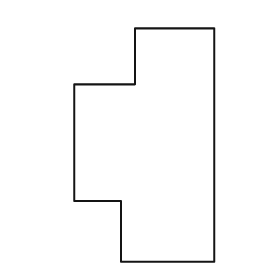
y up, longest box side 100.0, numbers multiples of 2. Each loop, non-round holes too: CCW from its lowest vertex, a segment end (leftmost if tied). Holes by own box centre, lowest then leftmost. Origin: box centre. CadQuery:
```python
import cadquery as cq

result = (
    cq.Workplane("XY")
    .moveTo(-10.0, -50.0)
    .lineTo(30.0, -50.0)
    .lineTo(30.0, 50.0)
    .lineTo(-4.0, 50.0)
    .lineTo(-4.0, 26.0)
    .lineTo(-30.0, 26.0)
    .lineTo(-30.0, -24.0)
    .lineTo(-10.0, -24.0)
    .close()
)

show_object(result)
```